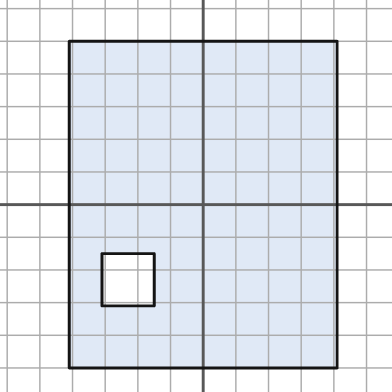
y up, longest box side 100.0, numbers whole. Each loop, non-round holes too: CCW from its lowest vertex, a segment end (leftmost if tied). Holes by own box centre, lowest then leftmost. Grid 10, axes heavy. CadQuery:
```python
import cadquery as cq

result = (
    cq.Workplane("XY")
    .moveTo(-41.0, -50.0)
    .lineTo(41.0, -50.0)
    .lineTo(41.0, 50.0)
    .lineTo(-41.0, 50.0)
    .close()
    .moveTo(-31.0, -31.0)
    .lineTo(-15.0, -31.0)
    .lineTo(-15.0, -15.0)
    .lineTo(-31.0, -15.0)
    .close()
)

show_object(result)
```